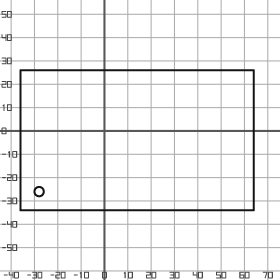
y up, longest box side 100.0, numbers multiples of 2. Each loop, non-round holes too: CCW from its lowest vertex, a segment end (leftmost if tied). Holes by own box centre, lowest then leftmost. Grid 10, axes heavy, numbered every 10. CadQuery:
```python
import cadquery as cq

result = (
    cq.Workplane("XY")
    .moveTo(-36.0, -34.0)
    .lineTo(64.0, -34.0)
    .lineTo(64.0, 26.0)
    .lineTo(-36.0, 26.0)
    .close()
    .moveTo(-28.0, -26.0)
    .circle(2.0)
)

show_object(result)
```